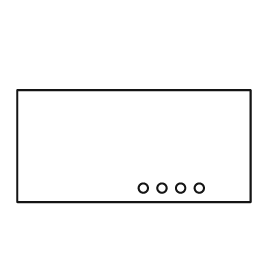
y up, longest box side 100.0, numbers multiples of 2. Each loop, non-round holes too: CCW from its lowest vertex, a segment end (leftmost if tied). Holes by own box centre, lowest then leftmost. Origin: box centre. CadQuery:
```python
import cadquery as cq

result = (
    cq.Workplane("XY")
    .moveTo(-50.0, -24.0)
    .lineTo(50.0, -24.0)
    .lineTo(50.0, 24.0)
    .lineTo(-50.0, 24.0)
    .close()
    .moveTo(4.0, -18.0)
    .circle(2.0)
    .moveTo(12.0, -18.0)
    .circle(2.0)
    .moveTo(20.0, -18.0)
    .circle(2.0)
    .moveTo(28.0, -18.0)
    .circle(2.0)
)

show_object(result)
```